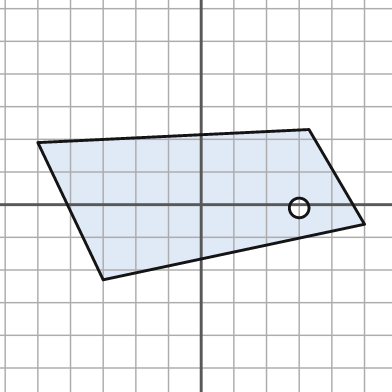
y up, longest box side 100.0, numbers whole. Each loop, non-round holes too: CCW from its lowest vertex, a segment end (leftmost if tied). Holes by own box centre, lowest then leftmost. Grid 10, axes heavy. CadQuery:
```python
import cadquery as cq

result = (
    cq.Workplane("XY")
    .moveTo(-30.0, -23.0)
    .lineTo(50.0, -6.0)
    .lineTo(33.0, 23.0)
    .lineTo(-50.0, 19.0)
    .close()
    .moveTo(30.0, -1.0)
    .circle(3.0)
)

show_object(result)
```